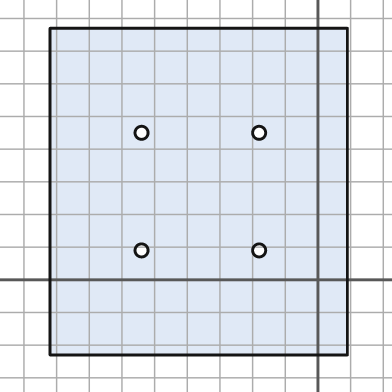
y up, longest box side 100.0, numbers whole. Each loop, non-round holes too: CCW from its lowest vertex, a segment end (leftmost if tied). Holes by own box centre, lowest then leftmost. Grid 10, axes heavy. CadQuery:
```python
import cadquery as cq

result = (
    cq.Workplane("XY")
    .moveTo(-82.0, -23.0)
    .lineTo(9.0, -23.0)
    .lineTo(9.0, 77.0)
    .lineTo(-82.0, 77.0)
    .close()
    .moveTo(-54.0, 9.0)
    .circle(2.0)
    .moveTo(-18.0, 9.0)
    .circle(2.0)
    .moveTo(-54.0, 45.0)
    .circle(2.0)
    .moveTo(-18.0, 45.0)
    .circle(2.0)
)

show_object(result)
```